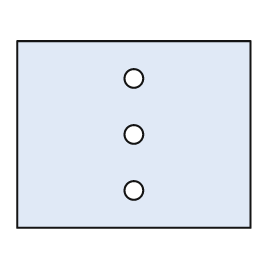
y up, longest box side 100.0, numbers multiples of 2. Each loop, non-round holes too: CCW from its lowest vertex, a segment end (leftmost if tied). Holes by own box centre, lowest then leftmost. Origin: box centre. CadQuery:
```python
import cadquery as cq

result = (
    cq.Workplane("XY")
    .moveTo(-50.0, -40.0)
    .lineTo(50.0, -40.0)
    .lineTo(50.0, 40.0)
    .lineTo(-50.0, 40.0)
    .close()
    .moveTo(0.0, -24.0)
    .circle(4.0)
    .moveTo(0.0, 0.0)
    .circle(4.0)
    .moveTo(0.0, 24.0)
    .circle(4.0)
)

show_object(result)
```